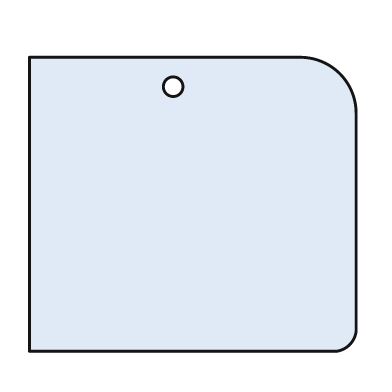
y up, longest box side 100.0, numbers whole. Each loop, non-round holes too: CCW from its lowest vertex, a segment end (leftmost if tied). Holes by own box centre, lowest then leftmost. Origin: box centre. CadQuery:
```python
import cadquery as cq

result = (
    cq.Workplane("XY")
    .moveTo(-50.0, -45.0)
    .lineTo(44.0, -45.0)
    .threePointArc((48.0, -43.0), (50.0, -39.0))
    .lineTo(50.0, 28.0)
    .threePointArc((45.0, 40.0), (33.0, 45.0))
    .lineTo(-50.0, 45.0)
    .close()
    .moveTo(-6.0, 36.0)
    .circle(3.0)
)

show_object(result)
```